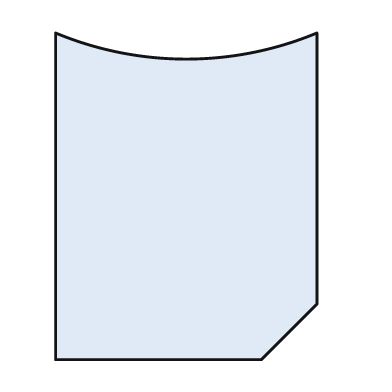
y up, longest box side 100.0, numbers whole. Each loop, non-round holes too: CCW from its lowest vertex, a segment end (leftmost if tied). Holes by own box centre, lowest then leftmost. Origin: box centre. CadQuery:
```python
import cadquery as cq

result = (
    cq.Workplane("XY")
    .moveTo(-40.0, -50.0)
    .lineTo(23.0, -50.0)
    .lineTo(40.0, -33.0)
    .lineTo(40.0, 50.0)
    .threePointArc((0.0, 42.0), (-40.0, 50.0))
    .close()
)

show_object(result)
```